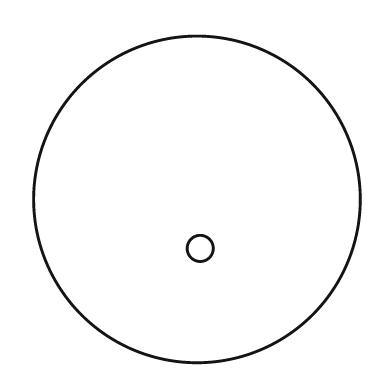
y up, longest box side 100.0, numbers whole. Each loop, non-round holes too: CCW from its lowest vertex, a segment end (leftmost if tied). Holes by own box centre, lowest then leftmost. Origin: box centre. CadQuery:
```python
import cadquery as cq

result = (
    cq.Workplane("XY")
    .moveTo(0.0, 0.0)
    .circle(50.0)
    .moveTo(1.0, -15.0)
    .circle(4.0)
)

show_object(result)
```